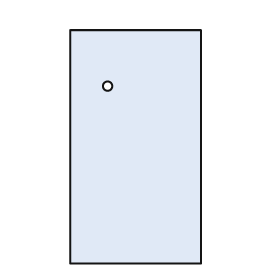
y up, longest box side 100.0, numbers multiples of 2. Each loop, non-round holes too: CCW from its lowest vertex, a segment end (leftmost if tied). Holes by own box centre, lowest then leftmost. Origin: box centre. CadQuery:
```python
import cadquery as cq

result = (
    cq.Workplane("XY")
    .moveTo(-28.0, -50.0)
    .lineTo(28.0, -50.0)
    .lineTo(28.0, 50.0)
    .lineTo(-28.0, 50.0)
    .close()
    .moveTo(-12.0, 26.0)
    .circle(2.0)
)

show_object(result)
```